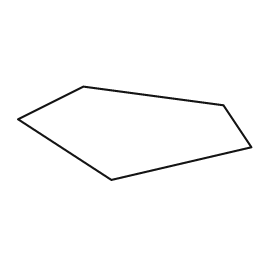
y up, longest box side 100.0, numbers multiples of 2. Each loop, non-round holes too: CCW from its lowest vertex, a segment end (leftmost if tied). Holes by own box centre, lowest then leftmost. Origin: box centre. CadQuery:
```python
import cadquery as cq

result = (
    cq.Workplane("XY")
    .moveTo(-10.0, -20.0)
    .lineTo(50.0, -6.0)
    .lineTo(38.0, 12.0)
    .lineTo(-22.0, 20.0)
    .lineTo(-50.0, 6.0)
    .close()
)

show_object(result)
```